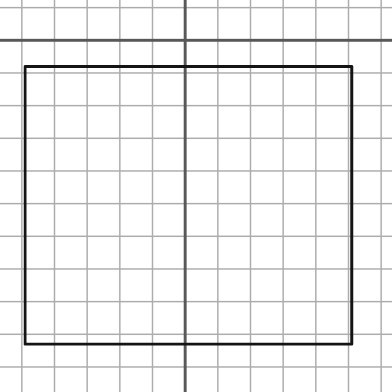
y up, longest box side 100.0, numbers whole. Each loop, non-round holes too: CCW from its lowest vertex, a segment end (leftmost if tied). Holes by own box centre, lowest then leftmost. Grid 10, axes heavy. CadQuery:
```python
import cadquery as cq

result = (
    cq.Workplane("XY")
    .moveTo(-49.0, -93.0)
    .lineTo(51.0, -93.0)
    .lineTo(51.0, -8.0)
    .lineTo(-49.0, -8.0)
    .close()
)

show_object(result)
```